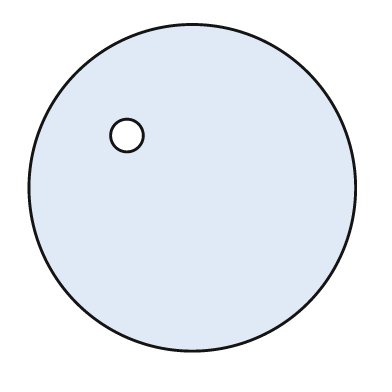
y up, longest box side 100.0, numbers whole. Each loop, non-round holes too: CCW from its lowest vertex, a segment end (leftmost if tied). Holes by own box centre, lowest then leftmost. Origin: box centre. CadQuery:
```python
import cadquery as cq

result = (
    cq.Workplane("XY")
    .moveTo(0.0, 0.0)
    .circle(50.0)
    .moveTo(-20.0, 16.0)
    .circle(5.0)
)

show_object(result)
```